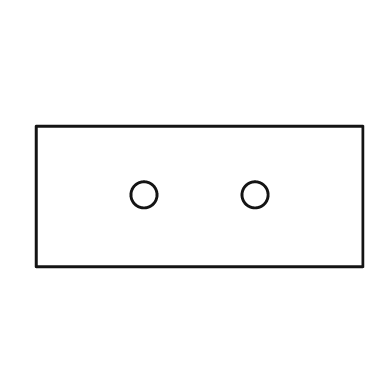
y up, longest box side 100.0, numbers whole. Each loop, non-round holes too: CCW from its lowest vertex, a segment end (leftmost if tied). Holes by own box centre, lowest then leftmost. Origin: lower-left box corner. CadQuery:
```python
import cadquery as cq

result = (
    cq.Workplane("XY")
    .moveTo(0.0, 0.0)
    .lineTo(100.0, 0.0)
    .lineTo(100.0, 43.0)
    .lineTo(0.0, 43.0)
    .close()
    .moveTo(33.0, 22.0)
    .circle(4.0)
    .moveTo(67.0, 22.0)
    .circle(4.0)
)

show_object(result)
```